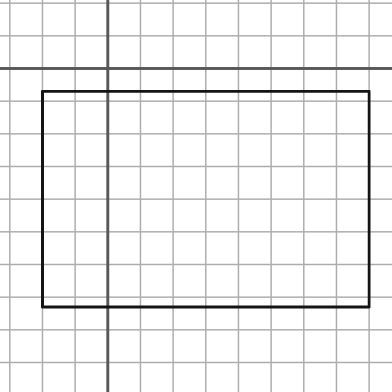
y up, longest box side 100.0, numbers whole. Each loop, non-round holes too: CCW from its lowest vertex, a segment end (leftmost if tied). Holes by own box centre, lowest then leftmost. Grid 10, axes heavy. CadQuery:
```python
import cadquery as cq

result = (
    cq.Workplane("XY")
    .moveTo(-20.0, -73.0)
    .lineTo(80.0, -73.0)
    .lineTo(80.0, -7.0)
    .lineTo(-20.0, -7.0)
    .close()
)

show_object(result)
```